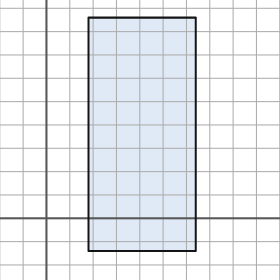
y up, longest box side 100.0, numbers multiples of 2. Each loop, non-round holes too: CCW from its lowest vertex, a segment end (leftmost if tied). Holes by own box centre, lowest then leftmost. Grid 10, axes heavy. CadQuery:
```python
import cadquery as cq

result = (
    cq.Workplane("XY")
    .moveTo(18.0, -14.0)
    .lineTo(64.0, -14.0)
    .lineTo(64.0, 86.0)
    .lineTo(18.0, 86.0)
    .close()
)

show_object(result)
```